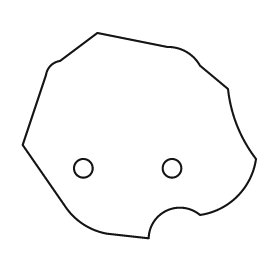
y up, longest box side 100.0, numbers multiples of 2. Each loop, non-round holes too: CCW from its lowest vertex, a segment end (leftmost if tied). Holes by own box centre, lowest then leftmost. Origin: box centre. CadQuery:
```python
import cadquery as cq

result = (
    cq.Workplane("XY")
    .moveTo(4.0, -44.0)
    .threePointArc((12.0, -32.0), (26.0, -34.0))
    .threePointArc((42.0, -26.0), (50.0, -10.0))
    .threePointArc((42.0, 4.0), (38.0, 20.0))
    .lineTo(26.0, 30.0)
    .threePointArc((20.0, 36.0), (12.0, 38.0))
    .lineTo(-18.0, 44.0)
    .lineTo(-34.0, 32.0)
    .threePointArc((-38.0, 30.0), (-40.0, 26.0))
    .lineTo(-50.0, -4.0)
    .lineTo(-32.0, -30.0)
    .threePointArc((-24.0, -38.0), (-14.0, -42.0))
    .close()
    .moveTo(-24.0, -14.0)
    .circle(4.0)
    .moveTo(14.0, -14.0)
    .circle(4.0)
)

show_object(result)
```